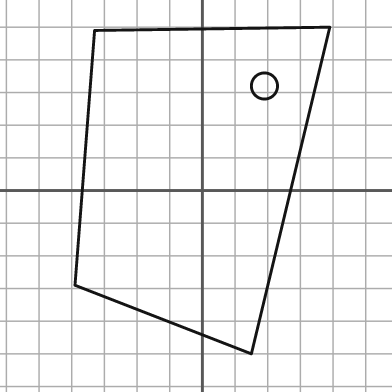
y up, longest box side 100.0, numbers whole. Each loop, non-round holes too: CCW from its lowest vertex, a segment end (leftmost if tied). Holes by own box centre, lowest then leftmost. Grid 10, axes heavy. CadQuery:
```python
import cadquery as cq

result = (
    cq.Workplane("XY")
    .moveTo(15.0, -50.0)
    .lineTo(39.0, 50.0)
    .lineTo(-33.0, 49.0)
    .lineTo(-39.0, -29.0)
    .close()
    .moveTo(19.0, 32.0)
    .circle(4.0)
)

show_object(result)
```